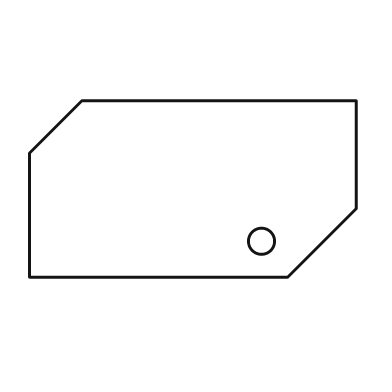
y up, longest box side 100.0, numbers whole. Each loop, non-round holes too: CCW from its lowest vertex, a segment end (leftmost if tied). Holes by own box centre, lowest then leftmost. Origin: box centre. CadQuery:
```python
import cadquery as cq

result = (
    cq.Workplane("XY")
    .moveTo(-50.0, -27.0)
    .lineTo(29.0, -27.0)
    .lineTo(50.0, -6.0)
    .lineTo(50.0, 27.0)
    .lineTo(-34.0, 27.0)
    .lineTo(-50.0, 11.0)
    .close()
    .moveTo(21.0, -16.0)
    .circle(4.0)
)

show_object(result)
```